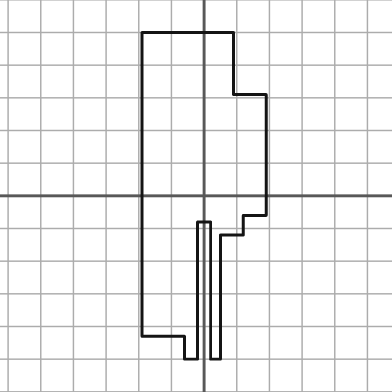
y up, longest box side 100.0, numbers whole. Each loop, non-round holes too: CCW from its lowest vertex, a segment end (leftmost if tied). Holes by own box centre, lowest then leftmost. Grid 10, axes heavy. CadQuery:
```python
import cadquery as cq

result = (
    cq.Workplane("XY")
    .moveTo(-6.0, -50.0)
    .lineTo(-2.0, -50.0)
    .lineTo(-2.0, -8.0)
    .lineTo(2.0, -8.0)
    .lineTo(2.0, -50.0)
    .lineTo(5.0, -50.0)
    .lineTo(5.0, -12.0)
    .lineTo(12.0, -12.0)
    .lineTo(12.0, -6.0)
    .lineTo(19.0, -6.0)
    .lineTo(19.0, 31.0)
    .lineTo(9.0, 31.0)
    .lineTo(9.0, 50.0)
    .lineTo(-19.0, 50.0)
    .lineTo(-19.0, -43.0)
    .lineTo(-6.0, -43.0)
    .close()
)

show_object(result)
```